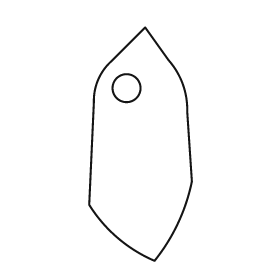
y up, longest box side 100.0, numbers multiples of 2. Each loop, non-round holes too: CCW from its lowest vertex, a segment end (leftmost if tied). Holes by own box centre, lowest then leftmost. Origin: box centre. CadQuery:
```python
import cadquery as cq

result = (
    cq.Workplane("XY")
    .moveTo(6.0, -50.0)
    .threePointArc((16.0, -34.0), (22.0, -16.0))
    .lineTo(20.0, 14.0)
    .threePointArc((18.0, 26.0), (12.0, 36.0))
    .lineTo(2.0, 50.0)
    .lineTo(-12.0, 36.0)
    .threePointArc((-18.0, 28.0), (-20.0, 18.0))
    .lineTo(-22.0, -26.0)
    .threePointArc((-10.0, -40.0), (6.0, -50.0))
    .close()
    .moveTo(-6.0, 24.0)
    .circle(6.0)
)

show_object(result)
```